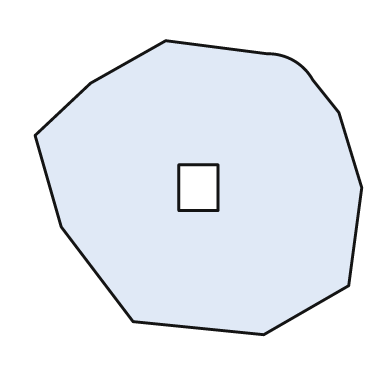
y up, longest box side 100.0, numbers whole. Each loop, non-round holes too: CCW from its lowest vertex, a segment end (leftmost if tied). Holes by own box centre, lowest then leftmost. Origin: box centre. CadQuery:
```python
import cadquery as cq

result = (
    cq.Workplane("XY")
    .moveTo(20.0, -45.0)
    .lineTo(46.0, -30.0)
    .lineTo(50.0, 0.0)
    .lineTo(43.0, 23.0)
    .lineTo(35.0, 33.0)
    .threePointArc((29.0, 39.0), (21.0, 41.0))
    .lineTo(-10.0, 45.0)
    .lineTo(-33.0, 32.0)
    .lineTo(-50.0, 16.0)
    .lineTo(-42.0, -12.0)
    .lineTo(-20.0, -41.0)
    .close()
    .moveTo(-6.0, -7.0)
    .lineTo(6.0, -7.0)
    .lineTo(6.0, 7.0)
    .lineTo(-6.0, 7.0)
    .close()
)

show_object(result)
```